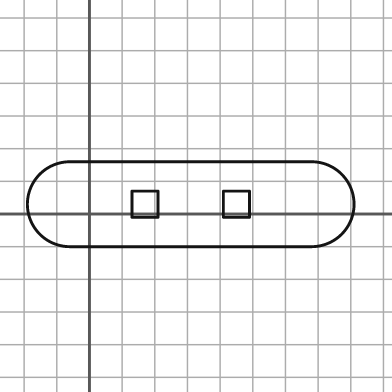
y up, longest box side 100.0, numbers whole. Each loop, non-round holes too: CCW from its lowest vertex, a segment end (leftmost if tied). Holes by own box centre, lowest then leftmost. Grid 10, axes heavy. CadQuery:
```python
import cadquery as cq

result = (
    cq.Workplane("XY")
    .moveTo(-6.0, -10.0)
    .lineTo(68.0, -10.0)
    .threePointArc((81.0, 3.0), (68.0, 16.0))
    .lineTo(-6.0, 16.0)
    .threePointArc((-19.0, 3.0), (-6.0, -10.0))
    .close()
    .moveTo(13.0, -1.0)
    .lineTo(21.0, -1.0)
    .lineTo(21.0, 7.0)
    .lineTo(13.0, 7.0)
    .close()
    .moveTo(41.0, -1.0)
    .lineTo(49.0, -1.0)
    .lineTo(49.0, 7.0)
    .lineTo(41.0, 7.0)
    .close()
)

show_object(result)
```